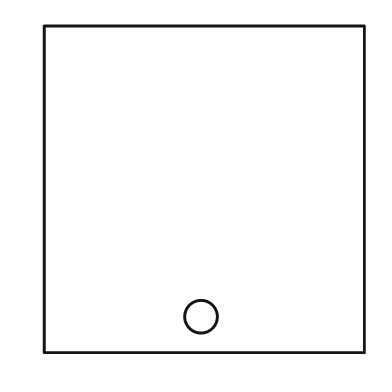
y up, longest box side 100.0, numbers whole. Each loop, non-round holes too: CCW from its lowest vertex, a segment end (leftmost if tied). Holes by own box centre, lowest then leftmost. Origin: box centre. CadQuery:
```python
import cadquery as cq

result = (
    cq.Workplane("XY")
    .moveTo(-49.0, -50.0)
    .lineTo(49.0, -50.0)
    .lineTo(49.0, 50.0)
    .lineTo(-49.0, 50.0)
    .close()
    .moveTo(-1.0, -39.0)
    .circle(5.0)
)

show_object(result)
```